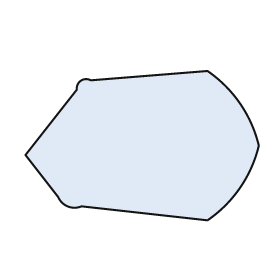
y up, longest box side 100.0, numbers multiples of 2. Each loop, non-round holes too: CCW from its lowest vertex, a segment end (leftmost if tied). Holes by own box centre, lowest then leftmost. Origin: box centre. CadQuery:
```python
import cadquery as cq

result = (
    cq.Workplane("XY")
    .moveTo(28.0, -32.0)
    .threePointArc((42.0, -18.0), (50.0, 0.0))
    .threePointArc((42.0, 18.0), (28.0, 32.0))
    .lineTo(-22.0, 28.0)
    .threePointArc((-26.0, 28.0), (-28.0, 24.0))
    .lineTo(-50.0, -4.0)
    .lineTo(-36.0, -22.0)
    .threePointArc((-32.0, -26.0), (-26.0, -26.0))
    .close()
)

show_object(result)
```